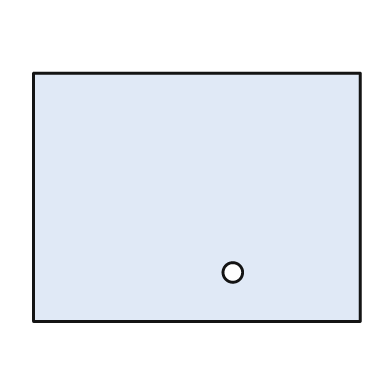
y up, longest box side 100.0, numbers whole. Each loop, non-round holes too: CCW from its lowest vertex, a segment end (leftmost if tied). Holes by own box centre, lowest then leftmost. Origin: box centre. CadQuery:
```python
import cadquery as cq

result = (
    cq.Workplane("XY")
    .moveTo(-50.0, -38.0)
    .lineTo(50.0, -38.0)
    .lineTo(50.0, 38.0)
    .lineTo(-50.0, 38.0)
    .close()
    .moveTo(11.0, -23.0)
    .circle(3.0)
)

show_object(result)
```